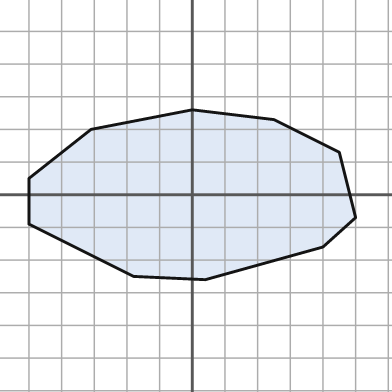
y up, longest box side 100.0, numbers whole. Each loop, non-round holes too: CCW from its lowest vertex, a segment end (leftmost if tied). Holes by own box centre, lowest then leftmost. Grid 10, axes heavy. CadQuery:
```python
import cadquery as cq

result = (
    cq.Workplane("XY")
    .moveTo(4.0, -26.0)
    .lineTo(40.0, -16.0)
    .lineTo(50.0, -7.0)
    .lineTo(45.0, 13.0)
    .lineTo(25.0, 23.0)
    .lineTo(0.0, 26.0)
    .lineTo(-31.0, 20.0)
    .lineTo(-50.0, 5.0)
    .lineTo(-50.0, -9.0)
    .lineTo(-18.0, -25.0)
    .close()
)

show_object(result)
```